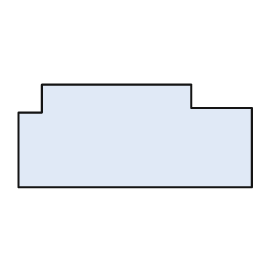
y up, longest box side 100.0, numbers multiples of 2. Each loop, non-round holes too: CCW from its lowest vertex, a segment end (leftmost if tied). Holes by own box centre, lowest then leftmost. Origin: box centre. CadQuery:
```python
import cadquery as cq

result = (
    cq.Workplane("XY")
    .moveTo(-50.0, -22.0)
    .lineTo(50.0, -22.0)
    .lineTo(50.0, 12.0)
    .lineTo(24.0, 12.0)
    .lineTo(24.0, 22.0)
    .lineTo(-40.0, 22.0)
    .lineTo(-40.0, 10.0)
    .lineTo(-50.0, 10.0)
    .close()
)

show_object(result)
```